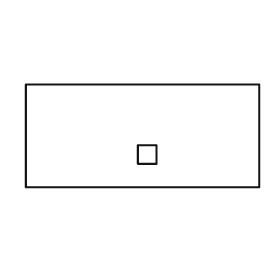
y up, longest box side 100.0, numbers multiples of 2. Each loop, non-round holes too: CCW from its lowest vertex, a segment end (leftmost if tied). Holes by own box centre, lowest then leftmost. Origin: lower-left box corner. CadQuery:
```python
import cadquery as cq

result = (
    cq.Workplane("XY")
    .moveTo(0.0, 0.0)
    .lineTo(100.0, 0.0)
    .lineTo(100.0, 44.0)
    .lineTo(0.0, 44.0)
    .close()
    .moveTo(48.0, 10.0)
    .lineTo(56.0, 10.0)
    .lineTo(56.0, 18.0)
    .lineTo(48.0, 18.0)
    .close()
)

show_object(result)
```